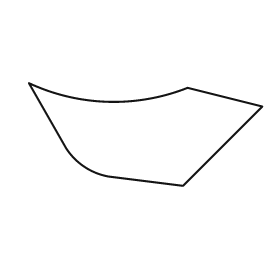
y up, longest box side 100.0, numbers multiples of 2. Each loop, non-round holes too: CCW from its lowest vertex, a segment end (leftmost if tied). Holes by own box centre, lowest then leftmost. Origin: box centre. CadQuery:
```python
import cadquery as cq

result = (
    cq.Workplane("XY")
    .moveTo(16.0, -22.0)
    .lineTo(50.0, 12.0)
    .lineTo(18.0, 20.0)
    .threePointArc((-16.0, 14.0), (-50.0, 22.0))
    .lineTo(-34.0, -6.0)
    .threePointArc((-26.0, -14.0), (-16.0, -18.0))
    .close()
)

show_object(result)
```